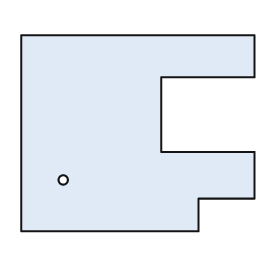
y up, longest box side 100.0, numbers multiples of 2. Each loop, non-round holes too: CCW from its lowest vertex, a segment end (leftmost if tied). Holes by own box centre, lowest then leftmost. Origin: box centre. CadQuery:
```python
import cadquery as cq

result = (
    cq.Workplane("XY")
    .moveTo(-50.0, -42.0)
    .lineTo(26.0, -42.0)
    .lineTo(26.0, -28.0)
    .lineTo(50.0, -28.0)
    .lineTo(50.0, -8.0)
    .lineTo(10.0, -8.0)
    .lineTo(10.0, 24.0)
    .lineTo(50.0, 24.0)
    .lineTo(50.0, 42.0)
    .lineTo(-50.0, 42.0)
    .close()
    .moveTo(-32.0, -20.0)
    .circle(2.0)
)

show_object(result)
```